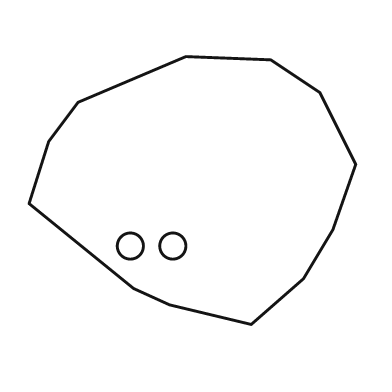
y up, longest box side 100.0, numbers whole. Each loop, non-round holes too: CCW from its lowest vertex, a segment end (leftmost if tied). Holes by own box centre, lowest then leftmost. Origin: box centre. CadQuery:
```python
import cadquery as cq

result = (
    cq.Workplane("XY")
    .moveTo(18.0, -41.0)
    .lineTo(34.0, -27.0)
    .lineTo(43.0, -12.0)
    .lineTo(50.0, 8.0)
    .lineTo(39.0, 30.0)
    .lineTo(24.0, 40.0)
    .lineTo(-2.0, 41.0)
    .lineTo(-35.0, 27.0)
    .lineTo(-44.0, 15.0)
    .lineTo(-50.0, -4.0)
    .lineTo(-18.0, -30.0)
    .lineTo(-7.0, -35.0)
    .close()
    .moveTo(-19.0, -17.0)
    .circle(4.0)
    .moveTo(-6.0, -17.0)
    .circle(4.0)
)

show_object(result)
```